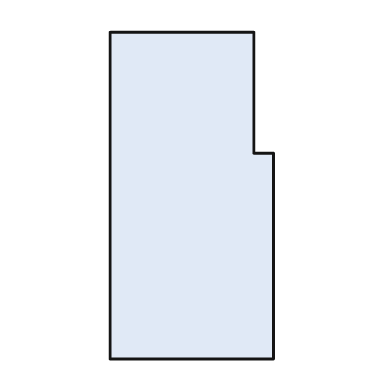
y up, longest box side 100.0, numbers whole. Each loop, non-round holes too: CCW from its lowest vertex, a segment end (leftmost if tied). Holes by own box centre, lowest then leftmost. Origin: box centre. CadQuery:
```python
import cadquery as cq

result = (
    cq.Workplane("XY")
    .moveTo(-25.0, -50.0)
    .lineTo(25.0, -50.0)
    .lineTo(25.0, 13.0)
    .lineTo(19.0, 13.0)
    .lineTo(19.0, 50.0)
    .lineTo(-25.0, 50.0)
    .close()
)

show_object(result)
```